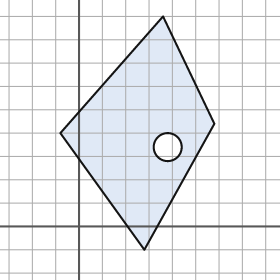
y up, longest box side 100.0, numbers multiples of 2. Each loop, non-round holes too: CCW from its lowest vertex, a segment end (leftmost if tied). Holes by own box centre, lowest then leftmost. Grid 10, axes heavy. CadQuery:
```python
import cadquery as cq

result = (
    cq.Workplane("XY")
    .moveTo(28.0, -10.0)
    .lineTo(58.0, 44.0)
    .lineTo(36.0, 90.0)
    .lineTo(-8.0, 40.0)
    .close()
    .moveTo(38.0, 34.0)
    .circle(6.0)
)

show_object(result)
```